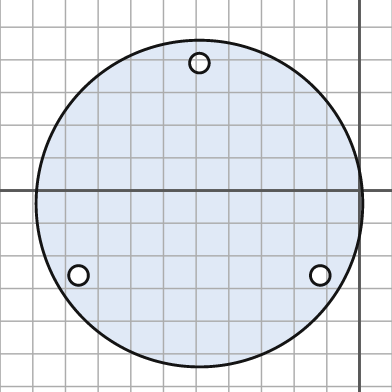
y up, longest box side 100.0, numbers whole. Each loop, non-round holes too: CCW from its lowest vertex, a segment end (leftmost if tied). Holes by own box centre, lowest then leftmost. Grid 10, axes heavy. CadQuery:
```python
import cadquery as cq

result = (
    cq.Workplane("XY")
    .moveTo(-49.0, -4.0)
    .circle(50.0)
    .moveTo(-86.0, -26.0)
    .circle(3.0)
    .moveTo(-12.0, -26.0)
    .circle(3.0)
    .moveTo(-49.0, 39.0)
    .circle(3.0)
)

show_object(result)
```